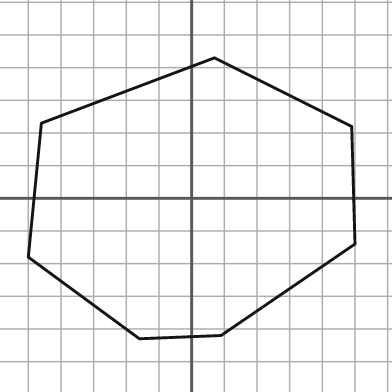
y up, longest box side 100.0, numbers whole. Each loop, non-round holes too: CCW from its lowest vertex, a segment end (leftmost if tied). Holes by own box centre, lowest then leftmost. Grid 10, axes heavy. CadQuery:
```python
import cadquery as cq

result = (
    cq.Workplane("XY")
    .moveTo(-16.0, -43.0)
    .lineTo(9.0, -42.0)
    .lineTo(50.0, -14.0)
    .lineTo(49.0, 22.0)
    .lineTo(7.0, 43.0)
    .lineTo(-46.0, 23.0)
    .lineTo(-50.0, -18.0)
    .close()
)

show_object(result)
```